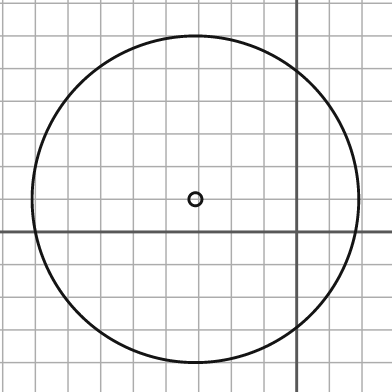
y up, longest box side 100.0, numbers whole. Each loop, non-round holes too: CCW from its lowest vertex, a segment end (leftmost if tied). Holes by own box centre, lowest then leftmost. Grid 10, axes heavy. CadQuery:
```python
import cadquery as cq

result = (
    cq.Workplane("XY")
    .moveTo(-31.0, 10.0)
    .circle(50.0)
    .moveTo(-31.0, 10.0)
    .circle(2.0)
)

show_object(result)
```